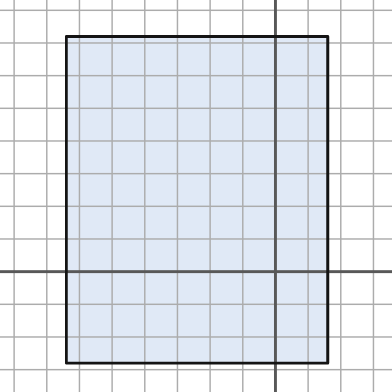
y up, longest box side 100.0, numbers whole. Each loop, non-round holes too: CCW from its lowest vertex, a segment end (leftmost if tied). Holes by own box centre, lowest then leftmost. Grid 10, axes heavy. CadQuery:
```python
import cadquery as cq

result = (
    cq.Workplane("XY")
    .moveTo(-64.0, -28.0)
    .lineTo(16.0, -28.0)
    .lineTo(16.0, 72.0)
    .lineTo(-64.0, 72.0)
    .close()
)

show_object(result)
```